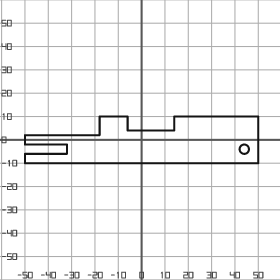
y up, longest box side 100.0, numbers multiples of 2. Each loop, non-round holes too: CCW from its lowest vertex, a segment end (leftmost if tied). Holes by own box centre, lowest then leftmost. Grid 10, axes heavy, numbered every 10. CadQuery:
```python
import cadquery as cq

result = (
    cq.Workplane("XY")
    .moveTo(-50.0, -10.0)
    .lineTo(50.0, -10.0)
    .lineTo(50.0, 10.0)
    .lineTo(14.0, 10.0)
    .lineTo(14.0, 4.0)
    .lineTo(-6.0, 4.0)
    .lineTo(-6.0, 10.0)
    .lineTo(-18.0, 10.0)
    .lineTo(-18.0, 2.0)
    .lineTo(-50.0, 2.0)
    .lineTo(-50.0, -2.0)
    .lineTo(-32.0, -2.0)
    .lineTo(-32.0, -6.0)
    .lineTo(-50.0, -6.0)
    .close()
    .moveTo(44.0, -4.0)
    .circle(2.0)
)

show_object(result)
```